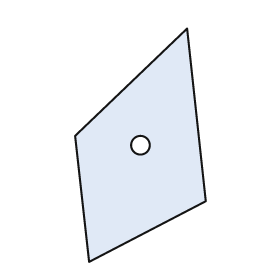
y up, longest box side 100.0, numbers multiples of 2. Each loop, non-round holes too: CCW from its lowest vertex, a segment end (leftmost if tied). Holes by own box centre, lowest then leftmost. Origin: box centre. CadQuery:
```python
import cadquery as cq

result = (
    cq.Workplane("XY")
    .moveTo(-22.0, -50.0)
    .lineTo(28.0, -24.0)
    .lineTo(20.0, 50.0)
    .lineTo(-28.0, 4.0)
    .close()
    .moveTo(0.0, 0.0)
    .circle(4.0)
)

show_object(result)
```